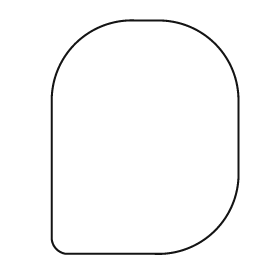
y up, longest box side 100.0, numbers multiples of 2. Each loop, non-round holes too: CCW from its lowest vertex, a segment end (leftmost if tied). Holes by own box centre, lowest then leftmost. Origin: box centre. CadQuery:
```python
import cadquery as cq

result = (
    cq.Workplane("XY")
    .moveTo(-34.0, -50.0)
    .lineTo(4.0, -50.0)
    .threePointArc((30.0, -40.0), (40.0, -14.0))
    .lineTo(40.0, 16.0)
    .threePointArc((30.0, 40.0), (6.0, 50.0))
    .lineTo(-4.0, 50.0)
    .threePointArc((-30.0, 40.0), (-40.0, 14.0))
    .lineTo(-40.0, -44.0)
    .threePointArc((-38.0, -48.0), (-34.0, -50.0))
    .close()
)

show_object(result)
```